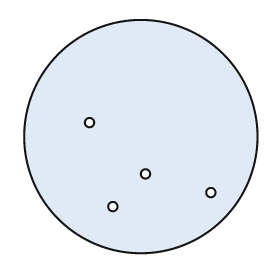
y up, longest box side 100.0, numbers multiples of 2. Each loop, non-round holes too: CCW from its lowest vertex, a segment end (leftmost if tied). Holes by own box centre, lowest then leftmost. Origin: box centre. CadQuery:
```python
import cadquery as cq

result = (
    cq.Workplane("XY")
    .moveTo(0.0, 0.0)
    .circle(50.0)
    .moveTo(-12.0, -30.0)
    .circle(2.0)
    .moveTo(30.0, -24.0)
    .circle(2.0)
    .moveTo(2.0, -16.0)
    .circle(2.0)
    .moveTo(-22.0, 6.0)
    .circle(2.0)
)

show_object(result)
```